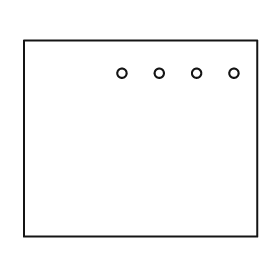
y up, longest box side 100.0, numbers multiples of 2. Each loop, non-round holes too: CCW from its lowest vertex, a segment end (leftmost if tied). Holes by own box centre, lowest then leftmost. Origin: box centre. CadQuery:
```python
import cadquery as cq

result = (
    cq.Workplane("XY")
    .moveTo(-50.0, -42.0)
    .lineTo(50.0, -42.0)
    .lineTo(50.0, 42.0)
    .lineTo(-50.0, 42.0)
    .close()
    .moveTo(-8.0, 28.0)
    .circle(2.0)
    .moveTo(8.0, 28.0)
    .circle(2.0)
    .moveTo(24.0, 28.0)
    .circle(2.0)
    .moveTo(40.0, 28.0)
    .circle(2.0)
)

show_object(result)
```